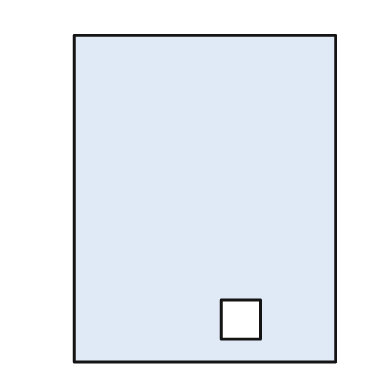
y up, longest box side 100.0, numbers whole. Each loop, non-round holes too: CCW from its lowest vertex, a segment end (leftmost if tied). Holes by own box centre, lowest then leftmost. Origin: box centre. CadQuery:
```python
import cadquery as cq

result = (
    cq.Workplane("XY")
    .moveTo(-40.0, -50.0)
    .lineTo(40.0, -50.0)
    .lineTo(40.0, 50.0)
    .lineTo(-40.0, 50.0)
    .close()
    .moveTo(5.0, -43.0)
    .lineTo(17.0, -43.0)
    .lineTo(17.0, -31.0)
    .lineTo(5.0, -31.0)
    .close()
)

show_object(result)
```